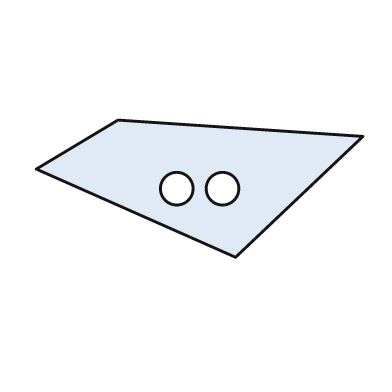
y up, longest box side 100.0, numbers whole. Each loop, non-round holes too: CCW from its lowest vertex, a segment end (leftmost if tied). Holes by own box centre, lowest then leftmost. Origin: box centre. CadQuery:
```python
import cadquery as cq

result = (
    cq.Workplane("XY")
    .moveTo(11.0, -21.0)
    .lineTo(50.0, 16.0)
    .lineTo(-25.0, 21.0)
    .lineTo(-50.0, 6.0)
    .close()
    .moveTo(-7.0, 0.0)
    .circle(5.0)
    .moveTo(7.0, 0.0)
    .circle(5.0)
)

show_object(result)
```